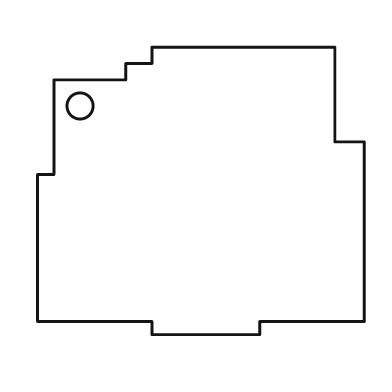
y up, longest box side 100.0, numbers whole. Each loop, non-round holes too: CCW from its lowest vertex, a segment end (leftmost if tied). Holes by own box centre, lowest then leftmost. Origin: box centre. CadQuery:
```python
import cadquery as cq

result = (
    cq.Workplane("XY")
    .moveTo(-15.0, -44.0)
    .lineTo(18.0, -44.0)
    .lineTo(18.0, -40.0)
    .lineTo(50.0, -40.0)
    .lineTo(50.0, 15.0)
    .lineTo(41.0, 15.0)
    .lineTo(41.0, 44.0)
    .lineTo(-15.0, 44.0)
    .lineTo(-15.0, 39.0)
    .lineTo(-23.0, 39.0)
    .lineTo(-23.0, 34.0)
    .lineTo(-45.0, 34.0)
    .lineTo(-45.0, 5.0)
    .lineTo(-50.0, 5.0)
    .lineTo(-50.0, -40.0)
    .lineTo(-15.0, -40.0)
    .close()
    .moveTo(-37.0, 26.0)
    .circle(4.0)
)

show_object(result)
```